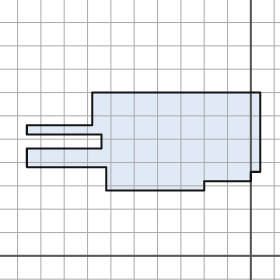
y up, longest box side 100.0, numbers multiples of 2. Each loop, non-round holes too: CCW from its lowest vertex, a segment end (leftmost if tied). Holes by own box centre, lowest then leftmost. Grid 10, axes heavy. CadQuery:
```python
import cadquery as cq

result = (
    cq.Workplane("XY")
    .moveTo(-62.0, 28.0)
    .lineTo(-20.0, 28.0)
    .lineTo(-20.0, 32.0)
    .lineTo(0.0, 32.0)
    .lineTo(0.0, 36.0)
    .lineTo(4.0, 36.0)
    .lineTo(4.0, 70.0)
    .lineTo(-68.0, 70.0)
    .lineTo(-68.0, 56.0)
    .lineTo(-96.0, 56.0)
    .lineTo(-96.0, 52.0)
    .lineTo(-64.0, 52.0)
    .lineTo(-64.0, 46.0)
    .lineTo(-96.0, 46.0)
    .lineTo(-96.0, 38.0)
    .lineTo(-62.0, 38.0)
    .close()
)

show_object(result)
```